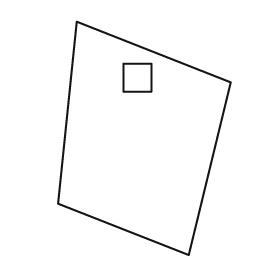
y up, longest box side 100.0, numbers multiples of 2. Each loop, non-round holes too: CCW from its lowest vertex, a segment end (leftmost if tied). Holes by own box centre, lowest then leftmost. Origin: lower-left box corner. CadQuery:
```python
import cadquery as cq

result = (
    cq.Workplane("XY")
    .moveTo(56.0, 0.0)
    .lineTo(74.0, 74.0)
    .lineTo(8.0, 100.0)
    .lineTo(0.0, 22.0)
    .close()
    .moveTo(28.0, 70.0)
    .lineTo(40.0, 70.0)
    .lineTo(40.0, 82.0)
    .lineTo(28.0, 82.0)
    .close()
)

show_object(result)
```